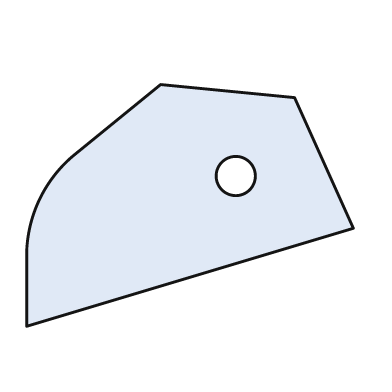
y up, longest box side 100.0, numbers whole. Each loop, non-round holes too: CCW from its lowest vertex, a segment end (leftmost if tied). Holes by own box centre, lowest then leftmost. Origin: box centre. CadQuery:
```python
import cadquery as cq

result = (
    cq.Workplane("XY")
    .moveTo(-50.0, -37.0)
    .lineTo(50.0, -7.0)
    .lineTo(32.0, 33.0)
    .lineTo(-9.0, 37.0)
    .lineTo(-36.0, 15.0)
    .threePointArc((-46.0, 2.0), (-50.0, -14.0))
    .close()
    .moveTo(14.0, 9.0)
    .circle(6.0)
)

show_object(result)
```